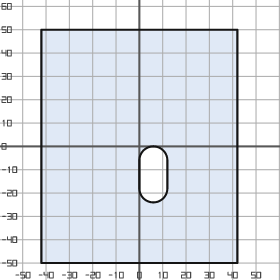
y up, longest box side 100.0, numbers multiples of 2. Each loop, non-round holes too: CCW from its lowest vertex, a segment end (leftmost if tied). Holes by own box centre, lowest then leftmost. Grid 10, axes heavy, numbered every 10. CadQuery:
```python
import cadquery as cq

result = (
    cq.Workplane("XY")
    .moveTo(-42.0, -50.0)
    .lineTo(42.0, -50.0)
    .lineTo(42.0, 50.0)
    .lineTo(-42.0, 50.0)
    .close()
    .moveTo(0.0, -18.0)
    .threePointArc((6.0, -24.0), (12.0, -18.0))
    .lineTo(12.0, -6.0)
    .threePointArc((6.0, 0.0), (0.0, -6.0))
    .close()
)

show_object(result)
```